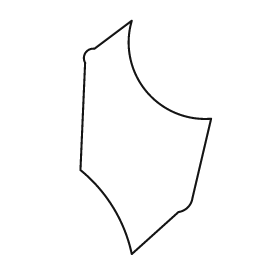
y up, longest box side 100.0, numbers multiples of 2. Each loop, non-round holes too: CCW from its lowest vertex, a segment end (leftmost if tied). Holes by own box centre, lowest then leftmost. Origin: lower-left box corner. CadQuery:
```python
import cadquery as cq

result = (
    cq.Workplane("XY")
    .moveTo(22.0, 0.0)
    .lineTo(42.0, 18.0)
    .threePointArc((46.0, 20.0), (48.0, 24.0))
    .lineTo(56.0, 58.0)
    .threePointArc((28.0, 70.0), (22.0, 100.0))
    .lineTo(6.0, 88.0)
    .threePointArc((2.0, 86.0), (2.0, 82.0))
    .lineTo(0.0, 36.0)
    .threePointArc((14.0, 20.0), (22.0, 0.0))
    .close()
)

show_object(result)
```